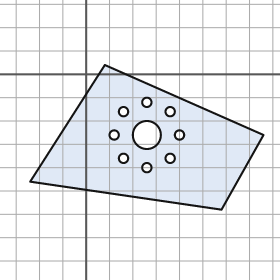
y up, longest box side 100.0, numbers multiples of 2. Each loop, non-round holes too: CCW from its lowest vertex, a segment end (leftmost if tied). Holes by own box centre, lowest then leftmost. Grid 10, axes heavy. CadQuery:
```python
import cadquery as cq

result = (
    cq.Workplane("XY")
    .moveTo(58.0, -58.0)
    .lineTo(76.0, -26.0)
    .lineTo(8.0, 4.0)
    .lineTo(-24.0, -46.0)
    .close()
    .moveTo(26.0, -40.0)
    .circle(2.0)
    .moveTo(16.0, -36.0)
    .circle(2.0)
    .moveTo(36.0, -36.0)
    .circle(2.0)
    .moveTo(12.0, -26.0)
    .circle(2.0)
    .moveTo(26.0, -26.0)
    .circle(6.0)
    .moveTo(40.0, -26.0)
    .circle(2.0)
    .moveTo(16.0, -16.0)
    .circle(2.0)
    .moveTo(36.0, -16.0)
    .circle(2.0)
    .moveTo(26.0, -12.0)
    .circle(2.0)
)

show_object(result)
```